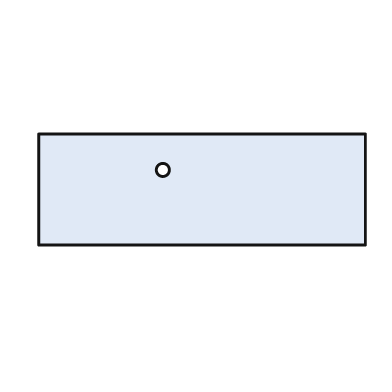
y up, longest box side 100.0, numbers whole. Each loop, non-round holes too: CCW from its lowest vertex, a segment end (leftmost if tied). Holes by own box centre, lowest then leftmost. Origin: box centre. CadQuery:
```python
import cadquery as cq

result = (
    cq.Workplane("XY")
    .moveTo(-50.0, -17.0)
    .lineTo(50.0, -17.0)
    .lineTo(50.0, 17.0)
    .lineTo(-50.0, 17.0)
    .close()
    .moveTo(-12.0, 6.0)
    .circle(2.0)
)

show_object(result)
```